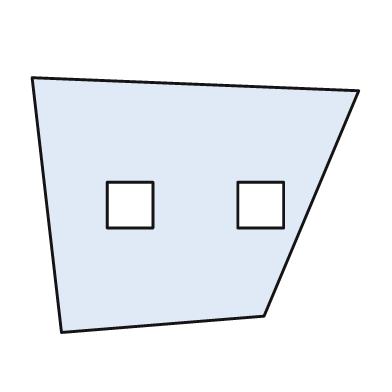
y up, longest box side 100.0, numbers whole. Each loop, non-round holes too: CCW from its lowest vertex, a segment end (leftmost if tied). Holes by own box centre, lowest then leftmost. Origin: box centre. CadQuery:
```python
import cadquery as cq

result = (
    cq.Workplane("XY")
    .moveTo(-41.0, -39.0)
    .lineTo(21.0, -34.0)
    .lineTo(50.0, 35.0)
    .lineTo(-50.0, 39.0)
    .close()
    .moveTo(-27.0, -7.0)
    .lineTo(-13.0, -7.0)
    .lineTo(-13.0, 7.0)
    .lineTo(-27.0, 7.0)
    .close()
    .moveTo(13.0, -7.0)
    .lineTo(27.0, -7.0)
    .lineTo(27.0, 7.0)
    .lineTo(13.0, 7.0)
    .close()
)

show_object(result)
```